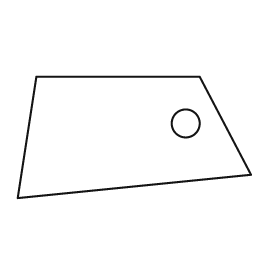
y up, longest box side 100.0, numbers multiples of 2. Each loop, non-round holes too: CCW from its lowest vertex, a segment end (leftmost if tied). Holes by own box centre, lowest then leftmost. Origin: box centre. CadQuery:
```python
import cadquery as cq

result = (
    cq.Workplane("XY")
    .moveTo(-50.0, -26.0)
    .lineTo(50.0, -16.0)
    .lineTo(28.0, 26.0)
    .lineTo(-42.0, 26.0)
    .close()
    .moveTo(22.0, 6.0)
    .circle(6.0)
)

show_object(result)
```